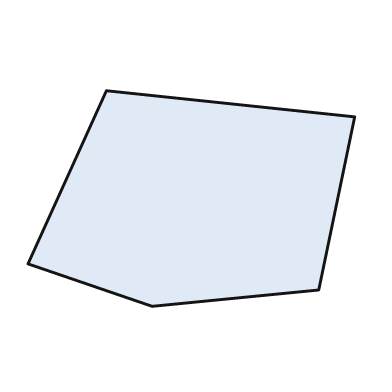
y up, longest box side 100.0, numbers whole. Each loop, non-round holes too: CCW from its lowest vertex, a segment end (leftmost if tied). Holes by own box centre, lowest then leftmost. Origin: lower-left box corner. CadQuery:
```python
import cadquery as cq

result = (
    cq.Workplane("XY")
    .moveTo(38.0, 0.0)
    .lineTo(89.0, 5.0)
    .lineTo(100.0, 58.0)
    .lineTo(24.0, 66.0)
    .lineTo(0.0, 13.0)
    .close()
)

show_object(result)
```